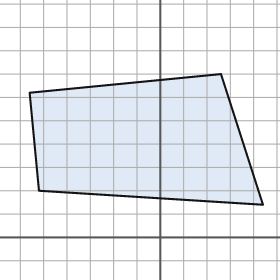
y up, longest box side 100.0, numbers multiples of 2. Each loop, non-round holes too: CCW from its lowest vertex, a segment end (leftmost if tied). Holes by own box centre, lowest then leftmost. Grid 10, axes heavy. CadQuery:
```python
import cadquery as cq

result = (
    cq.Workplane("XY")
    .moveTo(44.0, 14.0)
    .lineTo(26.0, 70.0)
    .lineTo(-56.0, 62.0)
    .lineTo(-52.0, 20.0)
    .close()
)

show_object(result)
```